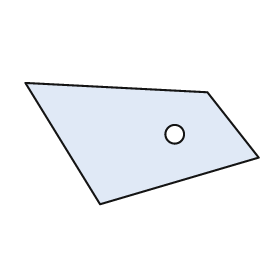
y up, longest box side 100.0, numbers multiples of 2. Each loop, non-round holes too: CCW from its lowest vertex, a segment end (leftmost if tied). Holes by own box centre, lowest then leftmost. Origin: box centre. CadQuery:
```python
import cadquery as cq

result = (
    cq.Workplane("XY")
    .moveTo(-18.0, -26.0)
    .lineTo(50.0, -6.0)
    .lineTo(28.0, 22.0)
    .lineTo(-50.0, 26.0)
    .close()
    .moveTo(14.0, 4.0)
    .circle(4.0)
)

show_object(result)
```